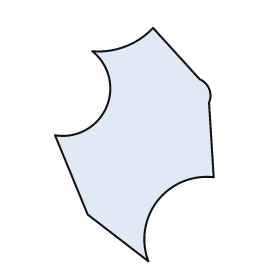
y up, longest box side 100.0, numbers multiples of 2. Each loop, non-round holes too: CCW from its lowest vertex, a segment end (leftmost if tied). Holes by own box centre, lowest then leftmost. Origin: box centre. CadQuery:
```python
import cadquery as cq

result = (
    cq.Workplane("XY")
    .moveTo(6.0, -50.0)
    .threePointArc((10.0, -24.0), (34.0, -14.0))
    .lineTo(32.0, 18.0)
    .threePointArc((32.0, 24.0), (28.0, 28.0))
    .lineTo(8.0, 50.0)
    .threePointArc((-4.0, 42.0), (-18.0, 40.0))
    .threePointArc((-12.0, 16.0), (-34.0, 4.0))
    .lineTo(-20.0, -30.0)
    .close()
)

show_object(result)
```